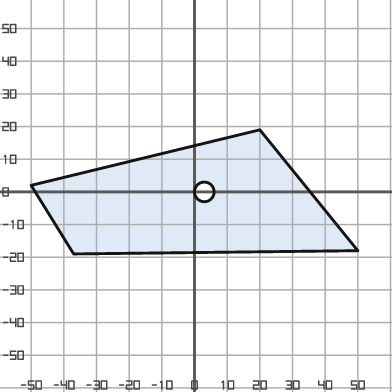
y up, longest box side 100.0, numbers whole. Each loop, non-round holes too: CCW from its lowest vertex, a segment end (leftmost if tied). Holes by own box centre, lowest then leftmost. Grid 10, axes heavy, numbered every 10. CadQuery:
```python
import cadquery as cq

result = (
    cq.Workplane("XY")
    .moveTo(-37.0, -19.0)
    .lineTo(50.0, -18.0)
    .lineTo(20.0, 19.0)
    .lineTo(-50.0, 2.0)
    .close()
    .moveTo(3.0, 0.0)
    .circle(3.0)
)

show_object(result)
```